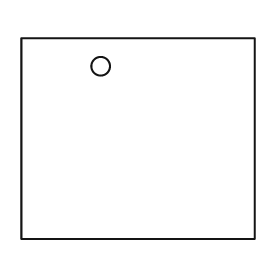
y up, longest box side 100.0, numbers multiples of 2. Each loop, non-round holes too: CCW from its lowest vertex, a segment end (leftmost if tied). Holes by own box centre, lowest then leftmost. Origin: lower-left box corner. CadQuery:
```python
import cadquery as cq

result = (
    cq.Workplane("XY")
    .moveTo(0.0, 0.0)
    .lineTo(100.0, 0.0)
    .lineTo(100.0, 86.0)
    .lineTo(0.0, 86.0)
    .close()
    .moveTo(34.0, 74.0)
    .circle(4.0)
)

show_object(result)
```